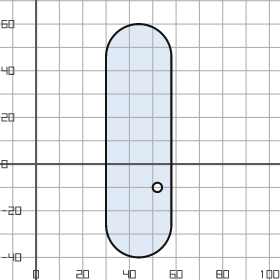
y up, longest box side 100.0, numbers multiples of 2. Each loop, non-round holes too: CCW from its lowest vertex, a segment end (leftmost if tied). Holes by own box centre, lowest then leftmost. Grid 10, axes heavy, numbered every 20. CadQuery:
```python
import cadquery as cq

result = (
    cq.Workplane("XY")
    .moveTo(30.0, -26.0)
    .threePointArc((44.0, -40.0), (58.0, -26.0))
    .lineTo(58.0, 46.0)
    .threePointArc((44.0, 60.0), (30.0, 46.0))
    .close()
    .moveTo(52.0, -10.0)
    .circle(2.0)
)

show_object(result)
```